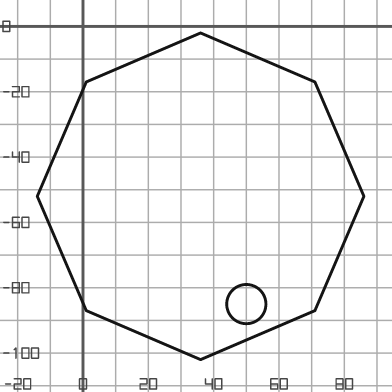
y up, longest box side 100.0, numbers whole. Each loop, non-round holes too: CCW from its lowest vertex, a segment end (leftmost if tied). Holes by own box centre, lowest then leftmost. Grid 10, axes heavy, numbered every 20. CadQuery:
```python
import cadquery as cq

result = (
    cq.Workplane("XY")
    .moveTo(36.0, -102.0)
    .lineTo(71.0, -87.0)
    .lineTo(86.0, -52.0)
    .lineTo(71.0, -17.0)
    .lineTo(36.0, -2.0)
    .lineTo(1.0, -17.0)
    .lineTo(-14.0, -52.0)
    .lineTo(1.0, -87.0)
    .close()
    .moveTo(50.0, -85.0)
    .circle(6.0)
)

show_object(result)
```